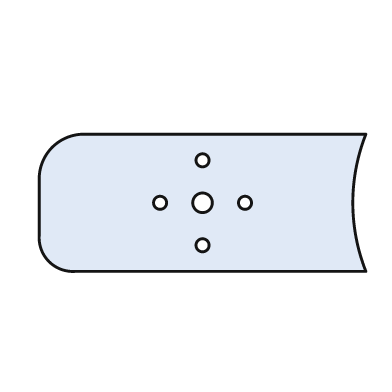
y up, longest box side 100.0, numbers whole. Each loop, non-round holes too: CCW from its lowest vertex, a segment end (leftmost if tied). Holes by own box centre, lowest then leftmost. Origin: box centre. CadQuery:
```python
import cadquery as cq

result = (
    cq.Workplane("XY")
    .moveTo(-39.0, -21.0)
    .lineTo(50.0, -21.0)
    .threePointArc((46.0, 0.0), (50.0, 21.0))
    .lineTo(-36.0, 21.0)
    .threePointArc((-46.0, 17.0), (-50.0, 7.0))
    .lineTo(-50.0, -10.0)
    .threePointArc((-47.0, -18.0), (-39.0, -21.0))
    .close()
    .moveTo(0.0, -13.0)
    .circle(2.0)
    .moveTo(-13.0, 0.0)
    .circle(2.0)
    .moveTo(0.0, 0.0)
    .circle(3.0)
    .moveTo(13.0, 0.0)
    .circle(2.0)
    .moveTo(0.0, 13.0)
    .circle(2.0)
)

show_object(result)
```